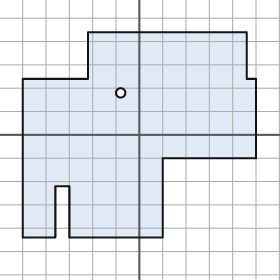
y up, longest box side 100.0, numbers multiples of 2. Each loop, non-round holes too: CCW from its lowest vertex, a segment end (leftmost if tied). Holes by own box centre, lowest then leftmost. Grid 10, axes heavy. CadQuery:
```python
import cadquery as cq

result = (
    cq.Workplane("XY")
    .moveTo(-50.0, -44.0)
    .lineTo(-36.0, -44.0)
    .lineTo(-36.0, -22.0)
    .lineTo(-30.0, -22.0)
    .lineTo(-30.0, -44.0)
    .lineTo(10.0, -44.0)
    .lineTo(10.0, -10.0)
    .lineTo(50.0, -10.0)
    .lineTo(50.0, 24.0)
    .lineTo(46.0, 24.0)
    .lineTo(46.0, 44.0)
    .lineTo(-22.0, 44.0)
    .lineTo(-22.0, 24.0)
    .lineTo(-50.0, 24.0)
    .close()
    .moveTo(-8.0, 18.0)
    .circle(2.0)
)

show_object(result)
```